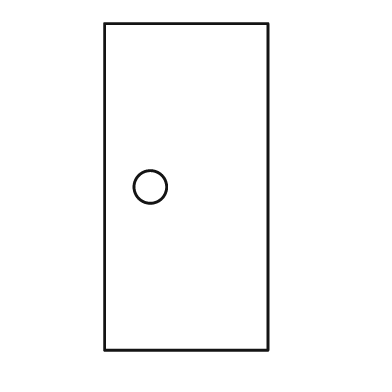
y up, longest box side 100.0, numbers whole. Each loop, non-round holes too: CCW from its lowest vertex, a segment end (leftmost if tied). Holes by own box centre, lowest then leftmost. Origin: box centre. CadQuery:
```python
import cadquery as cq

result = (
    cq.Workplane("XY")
    .moveTo(-25.0, -50.0)
    .lineTo(25.0, -50.0)
    .lineTo(25.0, 50.0)
    .lineTo(-25.0, 50.0)
    .close()
    .moveTo(-11.0, 0.0)
    .circle(5.0)
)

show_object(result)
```